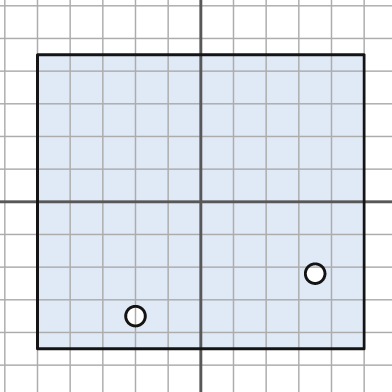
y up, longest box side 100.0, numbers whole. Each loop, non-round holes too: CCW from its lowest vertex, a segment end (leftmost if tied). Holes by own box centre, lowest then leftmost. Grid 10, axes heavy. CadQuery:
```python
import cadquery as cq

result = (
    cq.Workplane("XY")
    .moveTo(-50.0, -45.0)
    .lineTo(50.0, -45.0)
    .lineTo(50.0, 45.0)
    .lineTo(-50.0, 45.0)
    .close()
    .moveTo(-20.0, -35.0)
    .circle(3.0)
    .moveTo(35.0, -22.0)
    .circle(3.0)
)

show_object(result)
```